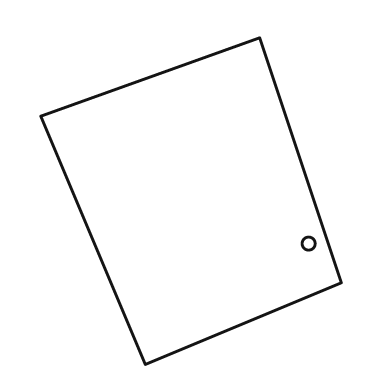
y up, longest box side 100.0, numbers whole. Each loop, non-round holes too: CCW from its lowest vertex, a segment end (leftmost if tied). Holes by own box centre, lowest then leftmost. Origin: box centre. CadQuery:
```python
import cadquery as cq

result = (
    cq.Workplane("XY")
    .moveTo(-14.0, -50.0)
    .lineTo(46.0, -25.0)
    .lineTo(21.0, 50.0)
    .lineTo(-46.0, 26.0)
    .close()
    .moveTo(36.0, -13.0)
    .circle(2.0)
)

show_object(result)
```